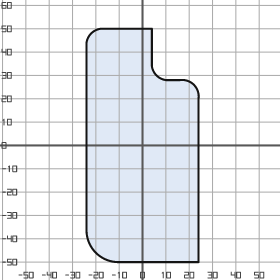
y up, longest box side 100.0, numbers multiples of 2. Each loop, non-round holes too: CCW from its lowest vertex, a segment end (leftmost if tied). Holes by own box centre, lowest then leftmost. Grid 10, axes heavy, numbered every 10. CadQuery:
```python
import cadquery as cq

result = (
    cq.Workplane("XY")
    .moveTo(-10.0, -50.0)
    .lineTo(24.0, -50.0)
    .lineTo(24.0, 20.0)
    .threePointArc((22.0, 26.0), (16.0, 28.0))
    .lineTo(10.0, 28.0)
    .threePointArc((6.0, 30.0), (4.0, 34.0))
    .lineTo(4.0, 50.0)
    .lineTo(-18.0, 50.0)
    .threePointArc((-22.0, 48.0), (-24.0, 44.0))
    .lineTo(-24.0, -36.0)
    .threePointArc((-20.0, -46.0), (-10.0, -50.0))
    .close()
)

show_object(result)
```